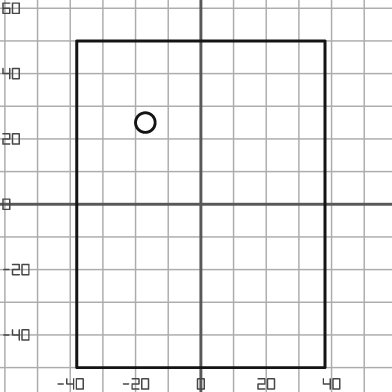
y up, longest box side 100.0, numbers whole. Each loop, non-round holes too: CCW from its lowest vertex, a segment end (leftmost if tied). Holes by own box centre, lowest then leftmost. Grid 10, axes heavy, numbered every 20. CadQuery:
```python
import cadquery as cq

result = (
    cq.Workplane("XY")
    .moveTo(-38.0, -50.0)
    .lineTo(38.0, -50.0)
    .lineTo(38.0, 50.0)
    .lineTo(-38.0, 50.0)
    .close()
    .moveTo(-17.0, 25.0)
    .circle(3.0)
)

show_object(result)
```